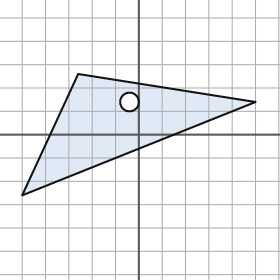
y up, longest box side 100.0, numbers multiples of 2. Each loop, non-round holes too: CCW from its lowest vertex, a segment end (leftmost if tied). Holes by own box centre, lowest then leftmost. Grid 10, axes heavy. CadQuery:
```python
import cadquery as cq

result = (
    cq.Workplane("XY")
    .moveTo(-50.0, -26.0)
    .lineTo(50.0, 14.0)
    .lineTo(-26.0, 26.0)
    .close()
    .moveTo(-4.0, 14.0)
    .circle(4.0)
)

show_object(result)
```